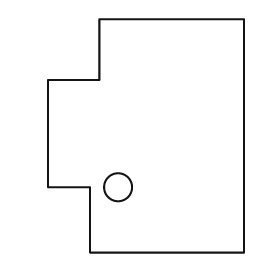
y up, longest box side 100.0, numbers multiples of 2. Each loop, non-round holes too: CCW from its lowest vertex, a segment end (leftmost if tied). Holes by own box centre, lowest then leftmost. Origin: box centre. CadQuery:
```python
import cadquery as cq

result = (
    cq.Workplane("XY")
    .moveTo(-24.0, -50.0)
    .lineTo(42.0, -50.0)
    .lineTo(42.0, 50.0)
    .lineTo(-20.0, 50.0)
    .lineTo(-20.0, 24.0)
    .lineTo(-42.0, 24.0)
    .lineTo(-42.0, -22.0)
    .lineTo(-24.0, -22.0)
    .close()
    .moveTo(-12.0, -22.0)
    .circle(6.0)
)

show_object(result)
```